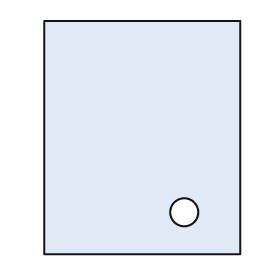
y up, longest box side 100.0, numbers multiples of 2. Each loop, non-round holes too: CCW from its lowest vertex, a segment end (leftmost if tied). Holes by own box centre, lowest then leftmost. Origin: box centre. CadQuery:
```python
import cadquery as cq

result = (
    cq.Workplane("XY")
    .moveTo(-42.0, -50.0)
    .lineTo(42.0, -50.0)
    .lineTo(42.0, 50.0)
    .lineTo(-42.0, 50.0)
    .close()
    .moveTo(18.0, -32.0)
    .circle(6.0)
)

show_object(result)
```